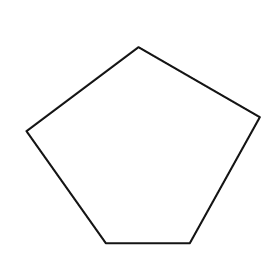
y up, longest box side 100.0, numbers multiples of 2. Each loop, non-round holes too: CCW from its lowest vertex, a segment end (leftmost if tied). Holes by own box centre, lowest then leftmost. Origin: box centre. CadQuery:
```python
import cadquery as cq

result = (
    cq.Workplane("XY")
    .moveTo(-16.0, -42.0)
    .lineTo(20.0, -42.0)
    .lineTo(50.0, 12.0)
    .lineTo(-2.0, 42.0)
    .lineTo(-50.0, 6.0)
    .close()
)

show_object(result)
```